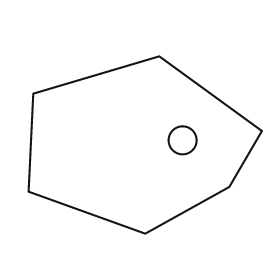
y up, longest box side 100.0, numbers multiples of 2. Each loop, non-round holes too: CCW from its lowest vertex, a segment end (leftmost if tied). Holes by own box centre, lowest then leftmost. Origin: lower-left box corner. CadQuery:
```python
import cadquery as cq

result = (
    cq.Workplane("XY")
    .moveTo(50.0, 0.0)
    .lineTo(86.0, 20.0)
    .lineTo(100.0, 44.0)
    .lineTo(56.0, 76.0)
    .lineTo(2.0, 60.0)
    .lineTo(0.0, 18.0)
    .close()
    .moveTo(66.0, 40.0)
    .circle(6.0)
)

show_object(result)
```